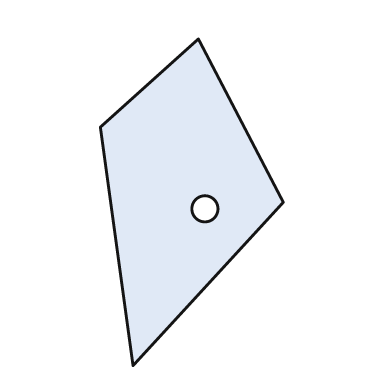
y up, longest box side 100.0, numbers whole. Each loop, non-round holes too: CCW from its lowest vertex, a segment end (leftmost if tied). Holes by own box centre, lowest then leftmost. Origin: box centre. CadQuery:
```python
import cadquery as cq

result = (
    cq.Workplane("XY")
    .moveTo(-18.0, -50.0)
    .lineTo(28.0, 0.0)
    .lineTo(2.0, 50.0)
    .lineTo(-28.0, 23.0)
    .close()
    .moveTo(4.0, -2.0)
    .circle(4.0)
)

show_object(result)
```